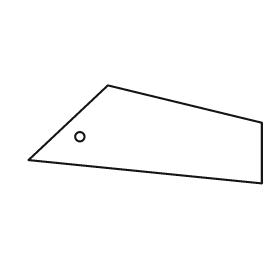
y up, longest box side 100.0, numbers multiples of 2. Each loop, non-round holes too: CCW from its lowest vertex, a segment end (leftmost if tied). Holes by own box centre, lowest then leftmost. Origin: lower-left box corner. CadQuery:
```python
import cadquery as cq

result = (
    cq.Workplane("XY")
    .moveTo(100.0, 0.0)
    .lineTo(100.0, 26.0)
    .lineTo(34.0, 42.0)
    .lineTo(0.0, 10.0)
    .close()
    .moveTo(22.0, 20.0)
    .circle(2.0)
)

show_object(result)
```